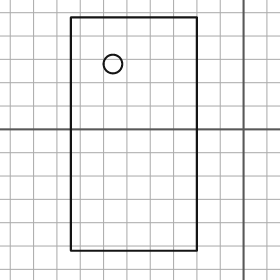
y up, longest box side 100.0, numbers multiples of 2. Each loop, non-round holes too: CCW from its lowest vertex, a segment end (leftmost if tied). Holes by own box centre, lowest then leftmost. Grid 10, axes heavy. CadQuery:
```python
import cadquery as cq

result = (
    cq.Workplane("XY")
    .moveTo(-74.0, -52.0)
    .lineTo(-20.0, -52.0)
    .lineTo(-20.0, 48.0)
    .lineTo(-74.0, 48.0)
    .close()
    .moveTo(-56.0, 28.0)
    .circle(4.0)
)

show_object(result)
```